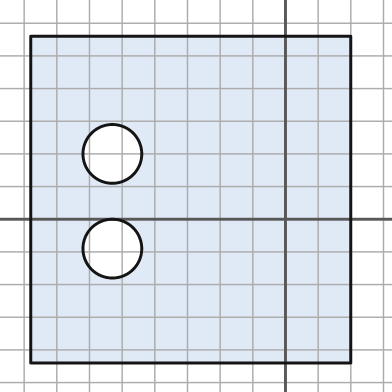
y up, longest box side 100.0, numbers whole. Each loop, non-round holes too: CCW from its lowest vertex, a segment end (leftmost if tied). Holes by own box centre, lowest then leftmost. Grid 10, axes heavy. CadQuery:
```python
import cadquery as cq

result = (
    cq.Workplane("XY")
    .moveTo(-78.0, -44.0)
    .lineTo(20.0, -44.0)
    .lineTo(20.0, 56.0)
    .lineTo(-78.0, 56.0)
    .close()
    .moveTo(-53.0, -9.0)
    .circle(9.0)
    .moveTo(-53.0, 20.0)
    .circle(9.0)
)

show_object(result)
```